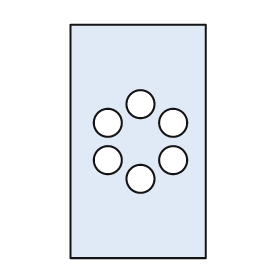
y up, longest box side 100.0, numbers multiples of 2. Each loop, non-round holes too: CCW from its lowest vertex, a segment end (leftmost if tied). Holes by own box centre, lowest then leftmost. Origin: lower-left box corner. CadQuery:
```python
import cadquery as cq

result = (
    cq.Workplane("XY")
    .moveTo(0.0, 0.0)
    .lineTo(58.0, 0.0)
    .lineTo(58.0, 100.0)
    .lineTo(0.0, 100.0)
    .close()
    .moveTo(30.0, 34.0)
    .circle(6.0)
    .moveTo(16.0, 42.0)
    .circle(6.0)
    .moveTo(44.0, 42.0)
    .circle(6.0)
    .moveTo(16.0, 58.0)
    .circle(6.0)
    .moveTo(44.0, 58.0)
    .circle(6.0)
    .moveTo(30.0, 66.0)
    .circle(6.0)
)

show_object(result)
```